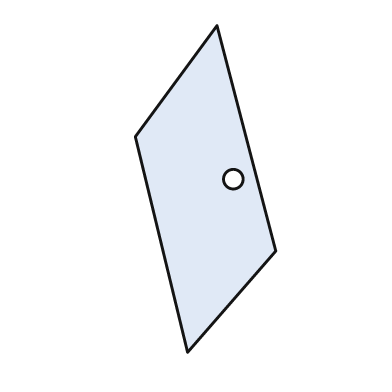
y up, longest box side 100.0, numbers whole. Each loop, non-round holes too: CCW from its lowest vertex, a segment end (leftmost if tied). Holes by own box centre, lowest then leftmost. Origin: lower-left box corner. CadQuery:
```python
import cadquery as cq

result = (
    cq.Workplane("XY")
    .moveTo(16.0, 0.0)
    .lineTo(43.0, 31.0)
    .lineTo(25.0, 100.0)
    .lineTo(0.0, 66.0)
    .close()
    .moveTo(30.0, 53.0)
    .circle(3.0)
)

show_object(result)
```